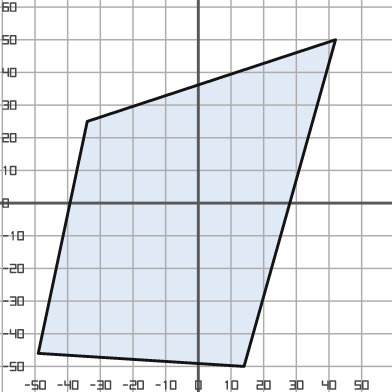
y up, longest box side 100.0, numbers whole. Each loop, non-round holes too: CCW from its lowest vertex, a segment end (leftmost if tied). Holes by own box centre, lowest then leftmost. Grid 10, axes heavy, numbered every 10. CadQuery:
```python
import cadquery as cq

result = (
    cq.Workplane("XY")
    .moveTo(14.0, -50.0)
    .lineTo(42.0, 50.0)
    .lineTo(-34.0, 25.0)
    .lineTo(-49.0, -46.0)
    .close()
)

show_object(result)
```